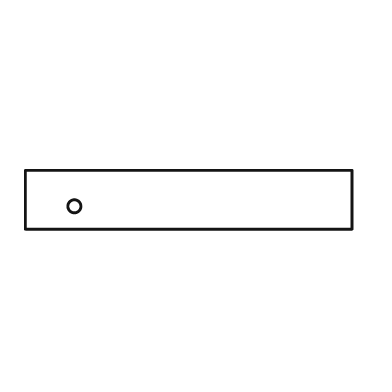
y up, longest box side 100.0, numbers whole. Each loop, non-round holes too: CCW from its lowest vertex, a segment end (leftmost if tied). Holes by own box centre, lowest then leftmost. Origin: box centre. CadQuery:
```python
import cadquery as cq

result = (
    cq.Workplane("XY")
    .moveTo(-50.0, -9.0)
    .lineTo(50.0, -9.0)
    .lineTo(50.0, 9.0)
    .lineTo(-50.0, 9.0)
    .close()
    .moveTo(-35.0, -2.0)
    .circle(2.0)
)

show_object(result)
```